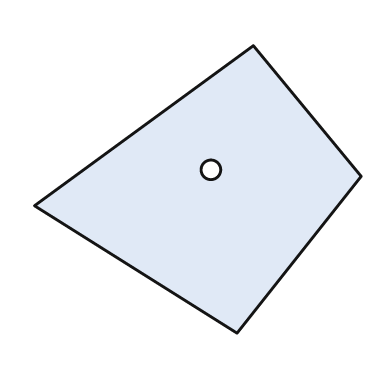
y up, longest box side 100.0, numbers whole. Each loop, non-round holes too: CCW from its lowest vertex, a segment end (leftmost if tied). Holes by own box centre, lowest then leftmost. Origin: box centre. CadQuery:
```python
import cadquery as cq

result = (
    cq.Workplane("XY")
    .moveTo(12.0, -44.0)
    .lineTo(50.0, 4.0)
    .lineTo(17.0, 44.0)
    .lineTo(-50.0, -5.0)
    .close()
    .moveTo(4.0, 6.0)
    .circle(3.0)
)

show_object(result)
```